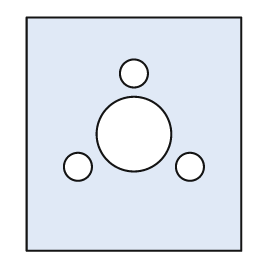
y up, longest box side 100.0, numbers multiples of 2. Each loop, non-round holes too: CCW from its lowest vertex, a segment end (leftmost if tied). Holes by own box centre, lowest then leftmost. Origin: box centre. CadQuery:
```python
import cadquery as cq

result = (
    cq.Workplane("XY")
    .moveTo(-46.0, -50.0)
    .lineTo(46.0, -50.0)
    .lineTo(46.0, 50.0)
    .lineTo(-46.0, 50.0)
    .close()
    .moveTo(-24.0, -14.0)
    .circle(6.0)
    .moveTo(24.0, -14.0)
    .circle(6.0)
    .moveTo(0.0, 0.0)
    .circle(16.0)
    .moveTo(0.0, 26.0)
    .circle(6.0)
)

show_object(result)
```